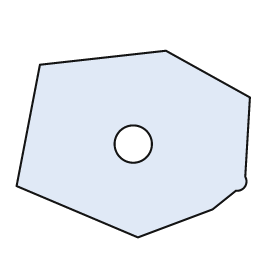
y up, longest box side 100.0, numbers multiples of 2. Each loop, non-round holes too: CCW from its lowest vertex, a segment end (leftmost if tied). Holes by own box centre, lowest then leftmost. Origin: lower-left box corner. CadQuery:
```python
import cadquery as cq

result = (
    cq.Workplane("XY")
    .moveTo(52.0, 0.0)
    .lineTo(84.0, 12.0)
    .lineTo(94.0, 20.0)
    .threePointArc((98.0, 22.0), (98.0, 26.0))
    .lineTo(100.0, 60.0)
    .lineTo(64.0, 80.0)
    .lineTo(10.0, 74.0)
    .lineTo(0.0, 22.0)
    .close()
    .moveTo(50.0, 40.0)
    .circle(8.0)
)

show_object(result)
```